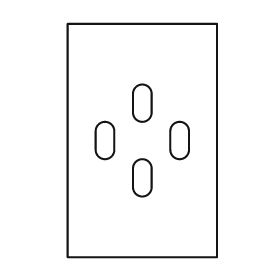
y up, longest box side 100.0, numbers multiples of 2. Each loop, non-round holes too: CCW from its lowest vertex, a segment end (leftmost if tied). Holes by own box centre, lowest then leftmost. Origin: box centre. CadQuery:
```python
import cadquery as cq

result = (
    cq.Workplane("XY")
    .moveTo(-32.0, -50.0)
    .lineTo(32.0, -50.0)
    .lineTo(32.0, 50.0)
    .lineTo(-32.0, 50.0)
    .close()
    .moveTo(-4.0, -20.0)
    .threePointArc((0.0, -24.0), (4.0, -20.0))
    .lineTo(4.0, -12.0)
    .threePointArc((0.0, -8.0), (-4.0, -12.0))
    .close()
    .moveTo(-20.0, -4.0)
    .threePointArc((-16.0, -8.0), (-12.0, -4.0))
    .lineTo(-12.0, 4.0)
    .threePointArc((-16.0, 8.0), (-20.0, 4.0))
    .close()
    .moveTo(12.0, -4.0)
    .threePointArc((16.0, -8.0), (20.0, -4.0))
    .lineTo(20.0, 4.0)
    .threePointArc((16.0, 8.0), (12.0, 4.0))
    .close()
    .moveTo(-4.0, 12.0)
    .threePointArc((0.0, 8.0), (4.0, 12.0))
    .lineTo(4.0, 20.0)
    .threePointArc((0.0, 24.0), (-4.0, 20.0))
    .close()
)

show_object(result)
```